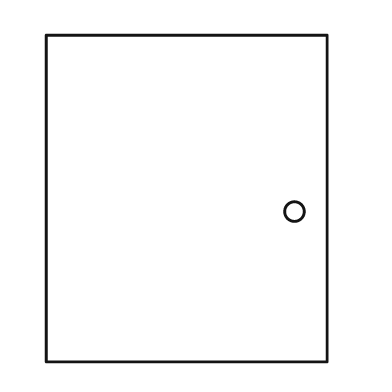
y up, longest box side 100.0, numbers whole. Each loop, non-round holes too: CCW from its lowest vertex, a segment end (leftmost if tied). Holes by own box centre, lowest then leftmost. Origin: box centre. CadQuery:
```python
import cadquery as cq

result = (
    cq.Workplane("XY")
    .moveTo(-43.0, -50.0)
    .lineTo(43.0, -50.0)
    .lineTo(43.0, 50.0)
    .lineTo(-43.0, 50.0)
    .close()
    .moveTo(33.0, -4.0)
    .circle(3.0)
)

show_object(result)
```